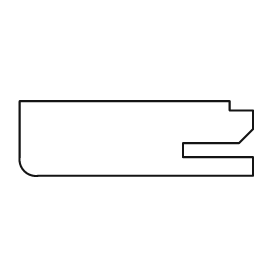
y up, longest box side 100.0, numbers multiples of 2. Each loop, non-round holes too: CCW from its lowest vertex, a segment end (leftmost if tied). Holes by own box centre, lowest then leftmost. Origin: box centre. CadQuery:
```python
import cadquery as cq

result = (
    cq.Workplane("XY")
    .moveTo(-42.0, -16.0)
    .lineTo(50.0, -16.0)
    .lineTo(50.0, -8.0)
    .lineTo(20.0, -8.0)
    .lineTo(20.0, -2.0)
    .lineTo(44.0, -2.0)
    .lineTo(50.0, 4.0)
    .lineTo(50.0, 12.0)
    .lineTo(40.0, 12.0)
    .lineTo(40.0, 16.0)
    .lineTo(-50.0, 16.0)
    .lineTo(-50.0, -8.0)
    .threePointArc((-48.0, -14.0), (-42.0, -16.0))
    .close()
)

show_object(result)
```